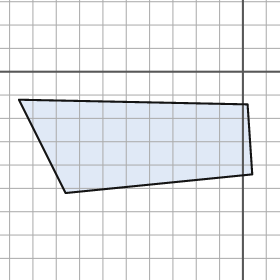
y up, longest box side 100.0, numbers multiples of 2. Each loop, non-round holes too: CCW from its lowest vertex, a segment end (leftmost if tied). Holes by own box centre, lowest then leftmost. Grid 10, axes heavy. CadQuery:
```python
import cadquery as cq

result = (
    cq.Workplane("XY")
    .moveTo(-76.0, -52.0)
    .lineTo(4.0, -44.0)
    .lineTo(2.0, -14.0)
    .lineTo(-96.0, -12.0)
    .close()
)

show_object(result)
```